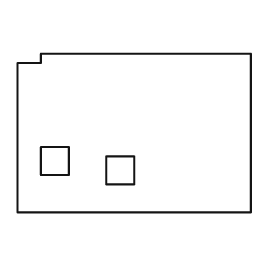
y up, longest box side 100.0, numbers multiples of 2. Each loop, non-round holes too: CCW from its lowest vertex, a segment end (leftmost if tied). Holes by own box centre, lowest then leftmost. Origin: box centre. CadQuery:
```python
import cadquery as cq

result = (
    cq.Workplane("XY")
    .moveTo(-50.0, -34.0)
    .lineTo(50.0, -34.0)
    .lineTo(50.0, 34.0)
    .lineTo(-40.0, 34.0)
    .lineTo(-40.0, 30.0)
    .lineTo(-50.0, 30.0)
    .close()
    .moveTo(-12.0, -22.0)
    .lineTo(0.0, -22.0)
    .lineTo(0.0, -10.0)
    .lineTo(-12.0, -10.0)
    .close()
    .moveTo(-40.0, -18.0)
    .lineTo(-28.0, -18.0)
    .lineTo(-28.0, -6.0)
    .lineTo(-40.0, -6.0)
    .close()
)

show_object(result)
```